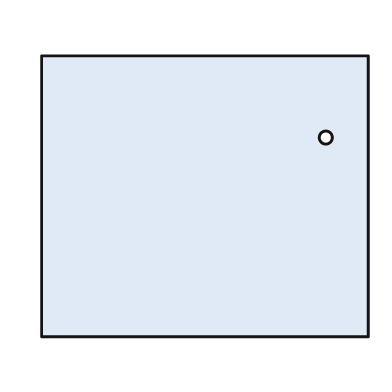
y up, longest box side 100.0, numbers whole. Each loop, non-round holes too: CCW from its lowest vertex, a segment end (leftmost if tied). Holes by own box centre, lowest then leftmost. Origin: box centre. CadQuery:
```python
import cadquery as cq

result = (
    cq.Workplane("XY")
    .moveTo(-50.0, -43.0)
    .lineTo(50.0, -43.0)
    .lineTo(50.0, 43.0)
    .lineTo(-50.0, 43.0)
    .close()
    .moveTo(37.0, 18.0)
    .circle(2.0)
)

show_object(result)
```